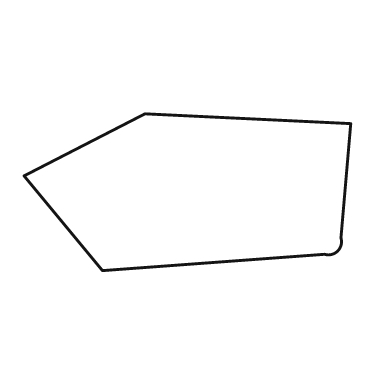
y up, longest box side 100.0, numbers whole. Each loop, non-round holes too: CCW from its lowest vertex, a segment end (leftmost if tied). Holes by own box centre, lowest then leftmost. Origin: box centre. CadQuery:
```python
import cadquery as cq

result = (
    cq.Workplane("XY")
    .moveTo(-26.0, -24.0)
    .lineTo(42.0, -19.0)
    .threePointArc((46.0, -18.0), (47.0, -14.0))
    .lineTo(50.0, 21.0)
    .lineTo(-13.0, 24.0)
    .lineTo(-50.0, 5.0)
    .close()
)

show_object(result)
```